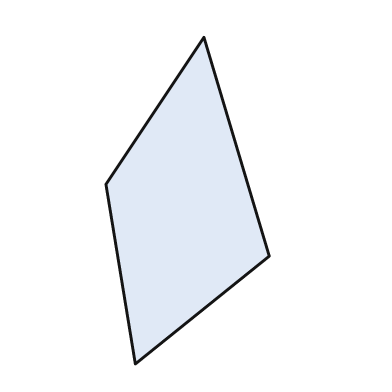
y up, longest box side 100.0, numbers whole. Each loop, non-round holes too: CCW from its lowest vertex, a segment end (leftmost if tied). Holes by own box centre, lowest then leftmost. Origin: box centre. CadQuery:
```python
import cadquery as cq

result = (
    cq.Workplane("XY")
    .moveTo(-16.0, -50.0)
    .lineTo(25.0, -17.0)
    .lineTo(5.0, 50.0)
    .lineTo(-25.0, 5.0)
    .close()
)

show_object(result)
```